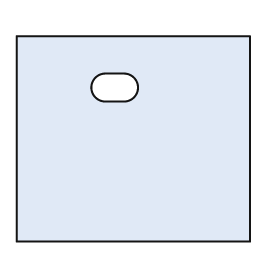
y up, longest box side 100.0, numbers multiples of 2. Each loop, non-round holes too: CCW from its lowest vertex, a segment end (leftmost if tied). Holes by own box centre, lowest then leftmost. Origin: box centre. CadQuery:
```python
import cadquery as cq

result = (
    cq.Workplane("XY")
    .moveTo(-50.0, -44.0)
    .lineTo(50.0, -44.0)
    .lineTo(50.0, 44.0)
    .lineTo(-50.0, 44.0)
    .close()
    .moveTo(-12.0, 16.0)
    .lineTo(-4.0, 16.0)
    .threePointArc((2.0, 22.0), (-4.0, 28.0))
    .lineTo(-12.0, 28.0)
    .threePointArc((-18.0, 22.0), (-12.0, 16.0))
    .close()
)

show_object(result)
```